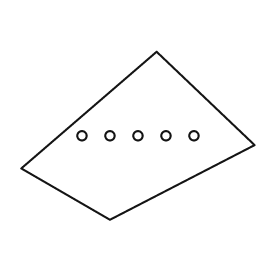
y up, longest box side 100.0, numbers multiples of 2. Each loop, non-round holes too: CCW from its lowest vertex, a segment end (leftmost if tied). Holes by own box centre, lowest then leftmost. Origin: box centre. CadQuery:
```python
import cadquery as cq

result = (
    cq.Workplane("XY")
    .moveTo(-12.0, -36.0)
    .lineTo(50.0, -4.0)
    .lineTo(8.0, 36.0)
    .lineTo(-50.0, -14.0)
    .close()
    .moveTo(-24.0, 0.0)
    .circle(2.0)
    .moveTo(-12.0, 0.0)
    .circle(2.0)
    .moveTo(0.0, 0.0)
    .circle(2.0)
    .moveTo(12.0, 0.0)
    .circle(2.0)
    .moveTo(24.0, 0.0)
    .circle(2.0)
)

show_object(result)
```